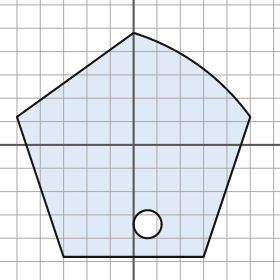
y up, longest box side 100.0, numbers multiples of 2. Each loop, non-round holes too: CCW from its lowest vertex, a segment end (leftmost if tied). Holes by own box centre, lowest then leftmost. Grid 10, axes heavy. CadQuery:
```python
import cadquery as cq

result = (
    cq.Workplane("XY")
    .moveTo(-30.0, -48.0)
    .lineTo(30.0, -48.0)
    .lineTo(50.0, 12.0)
    .threePointArc((28.0, 34.0), (0.0, 48.0))
    .lineTo(-50.0, 12.0)
    .close()
    .moveTo(6.0, -34.0)
    .circle(6.0)
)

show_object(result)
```